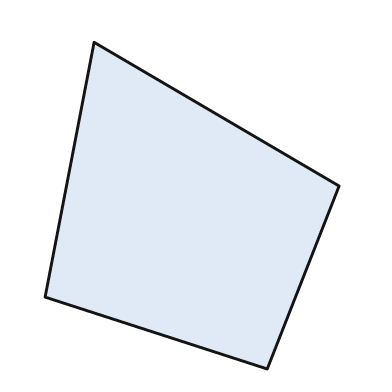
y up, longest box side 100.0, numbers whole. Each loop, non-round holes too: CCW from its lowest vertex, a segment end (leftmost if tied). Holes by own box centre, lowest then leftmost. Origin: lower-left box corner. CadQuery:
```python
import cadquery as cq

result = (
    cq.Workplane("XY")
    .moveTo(68.0, 0.0)
    .lineTo(90.0, 56.0)
    .lineTo(15.0, 100.0)
    .lineTo(0.0, 22.0)
    .close()
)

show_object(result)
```